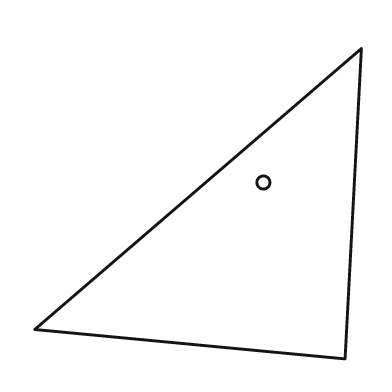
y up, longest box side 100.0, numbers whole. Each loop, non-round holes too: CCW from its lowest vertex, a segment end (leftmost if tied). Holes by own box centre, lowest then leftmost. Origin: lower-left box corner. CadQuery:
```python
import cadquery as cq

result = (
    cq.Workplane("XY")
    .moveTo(95.0, 0.0)
    .lineTo(100.0, 95.0)
    .lineTo(0.0, 9.0)
    .close()
    .moveTo(70.0, 54.0)
    .circle(2.0)
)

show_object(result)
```